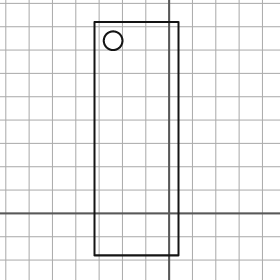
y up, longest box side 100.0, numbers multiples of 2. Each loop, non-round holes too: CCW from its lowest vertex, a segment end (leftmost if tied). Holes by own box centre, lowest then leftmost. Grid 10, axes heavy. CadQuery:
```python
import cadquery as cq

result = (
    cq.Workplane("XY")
    .moveTo(-32.0, -18.0)
    .lineTo(4.0, -18.0)
    .lineTo(4.0, 82.0)
    .lineTo(-32.0, 82.0)
    .close()
    .moveTo(-24.0, 74.0)
    .circle(4.0)
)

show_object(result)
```